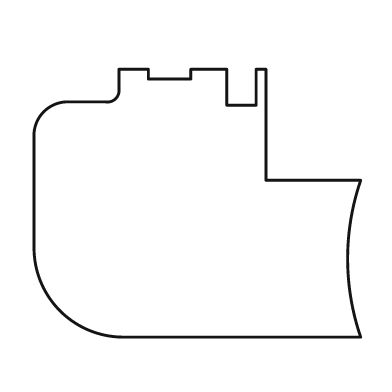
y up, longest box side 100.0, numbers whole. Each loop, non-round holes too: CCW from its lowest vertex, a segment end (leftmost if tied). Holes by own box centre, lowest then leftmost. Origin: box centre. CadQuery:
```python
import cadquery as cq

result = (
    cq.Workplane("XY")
    .moveTo(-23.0, -41.0)
    .lineTo(50.0, -41.0)
    .threePointArc((46.0, -17.0), (50.0, 7.0))
    .lineTo(21.0, 7.0)
    .lineTo(21.0, 41.0)
    .lineTo(18.0, 41.0)
    .lineTo(18.0, 30.0)
    .lineTo(9.0, 30.0)
    .lineTo(9.0, 41.0)
    .lineTo(-2.0, 41.0)
    .lineTo(-2.0, 38.0)
    .lineTo(-15.0, 38.0)
    .lineTo(-15.0, 41.0)
    .lineTo(-24.0, 41.0)
    .lineTo(-24.0, 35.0)
    .threePointArc((-25.0, 32.0), (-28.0, 31.0))
    .lineTo(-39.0, 31.0)
    .threePointArc((-47.0, 28.0), (-50.0, 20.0))
    .lineTo(-50.0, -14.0)
    .threePointArc((-42.0, -33.0), (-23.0, -41.0))
    .close()
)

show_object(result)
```